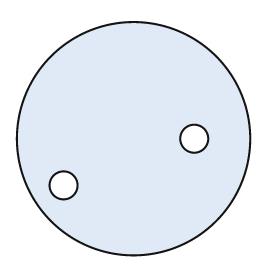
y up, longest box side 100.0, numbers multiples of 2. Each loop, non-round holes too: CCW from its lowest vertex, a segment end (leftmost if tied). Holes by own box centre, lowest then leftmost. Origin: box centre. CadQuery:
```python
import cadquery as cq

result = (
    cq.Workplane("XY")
    .moveTo(0.0, 0.0)
    .circle(50.0)
    .moveTo(-30.0, -20.0)
    .circle(6.0)
    .moveTo(26.0, 0.0)
    .circle(6.0)
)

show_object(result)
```